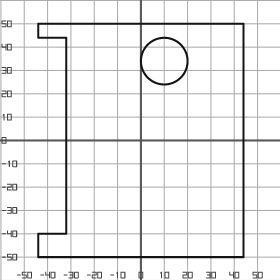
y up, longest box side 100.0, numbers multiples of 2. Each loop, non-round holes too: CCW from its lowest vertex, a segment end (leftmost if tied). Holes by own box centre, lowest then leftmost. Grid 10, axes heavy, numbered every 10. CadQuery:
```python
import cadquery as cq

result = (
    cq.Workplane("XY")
    .moveTo(-44.0, -50.0)
    .lineTo(44.0, -50.0)
    .lineTo(44.0, 50.0)
    .lineTo(-44.0, 50.0)
    .lineTo(-44.0, 44.0)
    .lineTo(-32.0, 44.0)
    .lineTo(-32.0, -40.0)
    .lineTo(-44.0, -40.0)
    .close()
    .moveTo(10.0, 34.0)
    .circle(10.0)
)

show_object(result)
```